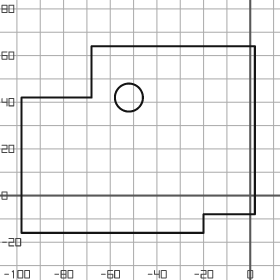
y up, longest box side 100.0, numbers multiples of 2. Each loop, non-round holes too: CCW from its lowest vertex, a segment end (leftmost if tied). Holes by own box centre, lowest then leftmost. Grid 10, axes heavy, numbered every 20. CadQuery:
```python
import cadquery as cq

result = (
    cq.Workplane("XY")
    .moveTo(-98.0, -16.0)
    .lineTo(-20.0, -16.0)
    .lineTo(-20.0, -8.0)
    .lineTo(2.0, -8.0)
    .lineTo(2.0, 64.0)
    .lineTo(-68.0, 64.0)
    .lineTo(-68.0, 42.0)
    .lineTo(-98.0, 42.0)
    .close()
    .moveTo(-52.0, 42.0)
    .circle(6.0)
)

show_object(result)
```